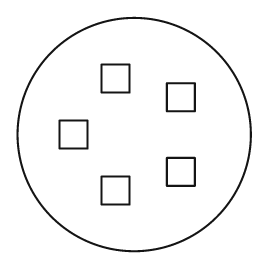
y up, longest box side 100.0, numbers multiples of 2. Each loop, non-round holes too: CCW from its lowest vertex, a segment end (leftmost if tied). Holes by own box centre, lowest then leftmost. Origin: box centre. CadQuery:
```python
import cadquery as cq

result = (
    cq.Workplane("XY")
    .moveTo(0.0, 0.0)
    .circle(50.0)
    .moveTo(-14.0, -30.0)
    .lineTo(-2.0, -30.0)
    .lineTo(-2.0, -18.0)
    .lineTo(-14.0, -18.0)
    .close()
    .moveTo(14.0, -22.0)
    .lineTo(26.0, -22.0)
    .lineTo(26.0, -10.0)
    .lineTo(14.0, -10.0)
    .close()
    .moveTo(-32.0, -6.0)
    .lineTo(-20.0, -6.0)
    .lineTo(-20.0, 6.0)
    .lineTo(-32.0, 6.0)
    .close()
    .moveTo(14.0, 10.0)
    .lineTo(26.0, 10.0)
    .lineTo(26.0, 22.0)
    .lineTo(14.0, 22.0)
    .close()
    .moveTo(-14.0, 18.0)
    .lineTo(-2.0, 18.0)
    .lineTo(-2.0, 30.0)
    .lineTo(-14.0, 30.0)
    .close()
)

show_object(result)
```